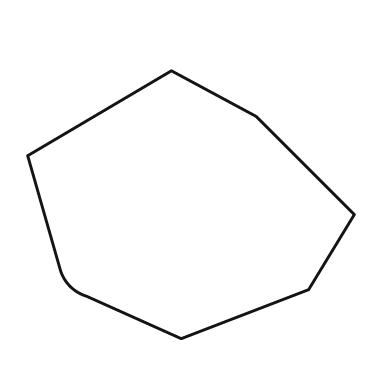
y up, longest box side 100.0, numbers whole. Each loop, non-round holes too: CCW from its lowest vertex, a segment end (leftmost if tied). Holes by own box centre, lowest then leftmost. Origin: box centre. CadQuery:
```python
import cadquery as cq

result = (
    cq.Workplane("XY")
    .moveTo(-3.0, -41.0)
    .lineTo(36.0, -26.0)
    .lineTo(50.0, -3.0)
    .lineTo(20.0, 27.0)
    .lineTo(-6.0, 41.0)
    .lineTo(-50.0, 15.0)
    .lineTo(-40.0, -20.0)
    .threePointArc((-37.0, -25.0), (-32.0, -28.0))
    .close()
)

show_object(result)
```